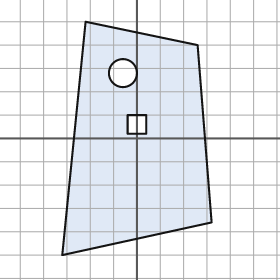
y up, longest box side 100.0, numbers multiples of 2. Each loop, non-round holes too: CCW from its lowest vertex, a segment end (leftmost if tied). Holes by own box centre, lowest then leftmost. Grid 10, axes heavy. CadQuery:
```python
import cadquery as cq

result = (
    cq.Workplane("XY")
    .moveTo(-32.0, -50.0)
    .lineTo(32.0, -36.0)
    .lineTo(26.0, 40.0)
    .lineTo(-22.0, 50.0)
    .close()
    .moveTo(-4.0, 2.0)
    .lineTo(4.0, 2.0)
    .lineTo(4.0, 10.0)
    .lineTo(-4.0, 10.0)
    .close()
    .moveTo(-6.0, 28.0)
    .circle(6.0)
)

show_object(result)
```